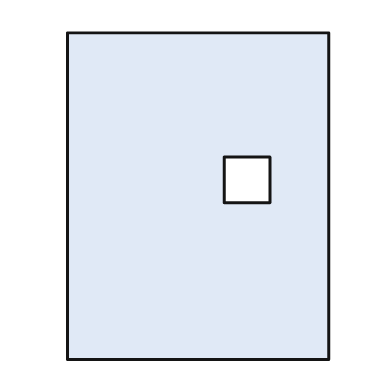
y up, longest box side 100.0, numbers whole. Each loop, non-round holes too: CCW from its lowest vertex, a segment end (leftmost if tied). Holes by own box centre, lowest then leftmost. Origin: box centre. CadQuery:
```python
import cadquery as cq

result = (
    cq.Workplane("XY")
    .moveTo(-40.0, -50.0)
    .lineTo(40.0, -50.0)
    .lineTo(40.0, 50.0)
    .lineTo(-40.0, 50.0)
    .close()
    .moveTo(8.0, -2.0)
    .lineTo(22.0, -2.0)
    .lineTo(22.0, 12.0)
    .lineTo(8.0, 12.0)
    .close()
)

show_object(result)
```